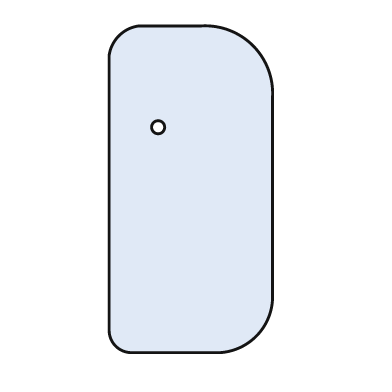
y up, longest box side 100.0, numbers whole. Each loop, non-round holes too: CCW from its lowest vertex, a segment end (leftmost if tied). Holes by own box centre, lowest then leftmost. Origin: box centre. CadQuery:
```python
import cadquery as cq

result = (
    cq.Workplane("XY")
    .moveTo(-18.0, -50.0)
    .lineTo(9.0, -50.0)
    .threePointArc((20.0, -45.0), (25.0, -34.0))
    .lineTo(25.0, 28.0)
    .threePointArc((19.0, 44.0), (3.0, 50.0))
    .lineTo(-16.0, 50.0)
    .threePointArc((-22.0, 47.0), (-25.0, 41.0))
    .lineTo(-25.0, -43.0)
    .threePointArc((-23.0, -48.0), (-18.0, -50.0))
    .close()
    .moveTo(-10.0, 19.0)
    .circle(2.0)
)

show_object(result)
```